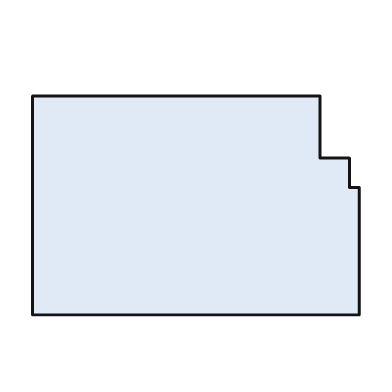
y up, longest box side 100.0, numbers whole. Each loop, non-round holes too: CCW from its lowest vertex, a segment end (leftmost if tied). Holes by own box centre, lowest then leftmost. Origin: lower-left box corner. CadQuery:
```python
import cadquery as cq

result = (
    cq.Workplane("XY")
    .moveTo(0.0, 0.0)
    .lineTo(100.0, 0.0)
    .lineTo(100.0, 39.0)
    .lineTo(97.0, 39.0)
    .lineTo(97.0, 48.0)
    .lineTo(88.0, 48.0)
    .lineTo(88.0, 67.0)
    .lineTo(0.0, 67.0)
    .close()
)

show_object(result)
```